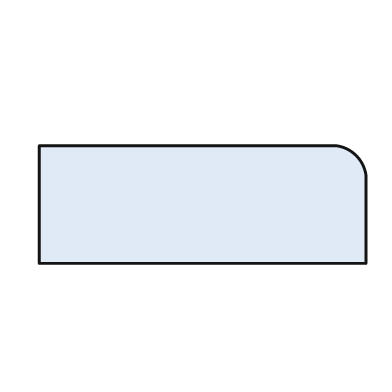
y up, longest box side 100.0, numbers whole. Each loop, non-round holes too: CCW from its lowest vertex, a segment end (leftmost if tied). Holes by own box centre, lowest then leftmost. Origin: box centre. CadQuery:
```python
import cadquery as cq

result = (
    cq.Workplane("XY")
    .moveTo(-50.0, -18.0)
    .lineTo(50.0, -18.0)
    .lineTo(50.0, 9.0)
    .threePointArc((47.0, 15.0), (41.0, 18.0))
    .lineTo(-50.0, 18.0)
    .close()
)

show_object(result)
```